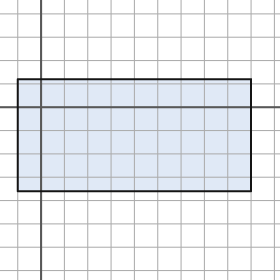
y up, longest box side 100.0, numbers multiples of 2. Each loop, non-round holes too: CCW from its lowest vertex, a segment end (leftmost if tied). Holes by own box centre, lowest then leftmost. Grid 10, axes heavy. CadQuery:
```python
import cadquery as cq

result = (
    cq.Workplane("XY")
    .moveTo(-10.0, -36.0)
    .lineTo(90.0, -36.0)
    .lineTo(90.0, 12.0)
    .lineTo(-10.0, 12.0)
    .close()
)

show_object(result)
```